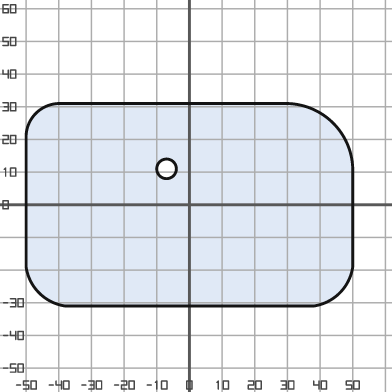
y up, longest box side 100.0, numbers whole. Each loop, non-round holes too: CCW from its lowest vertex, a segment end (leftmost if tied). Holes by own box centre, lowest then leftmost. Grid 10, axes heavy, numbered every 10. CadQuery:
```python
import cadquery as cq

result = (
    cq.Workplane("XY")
    .moveTo(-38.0, -31.0)
    .lineTo(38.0, -31.0)
    .threePointArc((46.0, -27.0), (50.0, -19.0))
    .lineTo(50.0, 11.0)
    .threePointArc((44.0, 25.0), (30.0, 31.0))
    .lineTo(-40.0, 31.0)
    .threePointArc((-47.0, 28.0), (-50.0, 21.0))
    .lineTo(-50.0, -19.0)
    .threePointArc((-46.0, -27.0), (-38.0, -31.0))
    .close()
    .moveTo(-7.0, 11.0)
    .circle(3.0)
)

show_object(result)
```